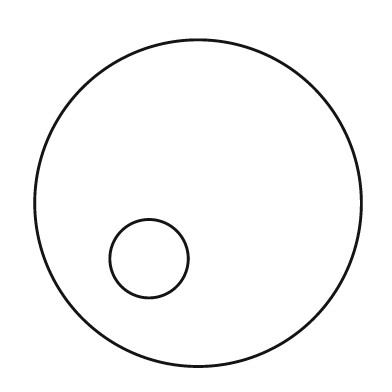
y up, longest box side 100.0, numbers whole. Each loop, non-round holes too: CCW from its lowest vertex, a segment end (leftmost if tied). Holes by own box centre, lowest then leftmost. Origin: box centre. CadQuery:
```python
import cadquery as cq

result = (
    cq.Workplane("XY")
    .moveTo(0.0, 0.0)
    .circle(50.0)
    .moveTo(-15.0, -17.0)
    .circle(12.0)
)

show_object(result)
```